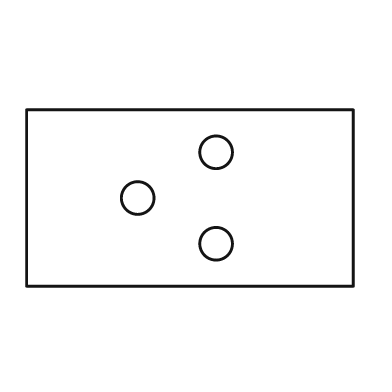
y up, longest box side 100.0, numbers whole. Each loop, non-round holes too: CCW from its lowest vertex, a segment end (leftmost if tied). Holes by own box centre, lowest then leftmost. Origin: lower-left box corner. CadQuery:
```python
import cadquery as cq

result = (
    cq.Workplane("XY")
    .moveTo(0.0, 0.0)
    .lineTo(100.0, 0.0)
    .lineTo(100.0, 54.0)
    .lineTo(0.0, 54.0)
    .close()
    .moveTo(58.0, 13.0)
    .circle(5.0)
    .moveTo(34.0, 27.0)
    .circle(5.0)
    .moveTo(58.0, 41.0)
    .circle(5.0)
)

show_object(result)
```